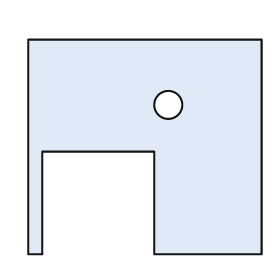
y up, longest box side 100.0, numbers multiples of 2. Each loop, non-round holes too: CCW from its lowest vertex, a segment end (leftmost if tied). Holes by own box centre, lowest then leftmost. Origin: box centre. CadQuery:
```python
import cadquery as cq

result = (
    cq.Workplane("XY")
    .moveTo(-50.0, -46.0)
    .lineTo(-44.0, -46.0)
    .lineTo(-44.0, -2.0)
    .lineTo(4.0, -2.0)
    .lineTo(4.0, -46.0)
    .lineTo(50.0, -46.0)
    .lineTo(50.0, 46.0)
    .lineTo(-50.0, 46.0)
    .close()
    .moveTo(10.0, 18.0)
    .circle(6.0)
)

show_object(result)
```